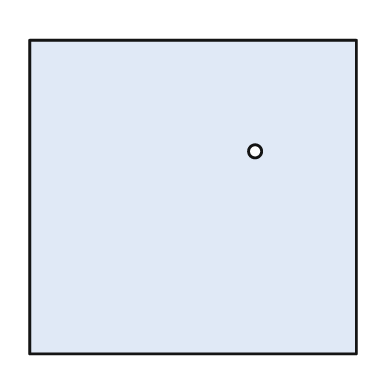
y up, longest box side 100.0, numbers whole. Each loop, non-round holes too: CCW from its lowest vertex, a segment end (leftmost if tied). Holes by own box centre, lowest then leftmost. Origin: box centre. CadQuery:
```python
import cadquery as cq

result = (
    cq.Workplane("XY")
    .moveTo(-50.0, -48.0)
    .lineTo(50.0, -48.0)
    .lineTo(50.0, 48.0)
    .lineTo(-50.0, 48.0)
    .close()
    .moveTo(19.0, 14.0)
    .circle(2.0)
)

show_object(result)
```